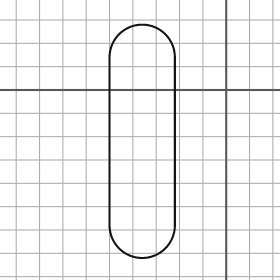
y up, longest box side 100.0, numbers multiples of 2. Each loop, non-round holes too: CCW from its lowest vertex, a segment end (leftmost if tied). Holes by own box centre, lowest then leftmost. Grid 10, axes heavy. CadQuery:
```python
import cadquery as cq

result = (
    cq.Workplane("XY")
    .moveTo(-50.0, -58.0)
    .threePointArc((-36.0, -72.0), (-22.0, -58.0))
    .lineTo(-22.0, 14.0)
    .threePointArc((-36.0, 28.0), (-50.0, 14.0))
    .close()
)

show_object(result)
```